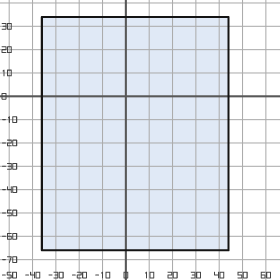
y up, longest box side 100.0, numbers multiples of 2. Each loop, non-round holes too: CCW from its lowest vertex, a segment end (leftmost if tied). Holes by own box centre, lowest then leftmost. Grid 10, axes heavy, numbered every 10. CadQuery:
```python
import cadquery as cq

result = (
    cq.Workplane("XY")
    .moveTo(-36.0, -66.0)
    .lineTo(44.0, -66.0)
    .lineTo(44.0, 34.0)
    .lineTo(-36.0, 34.0)
    .close()
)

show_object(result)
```